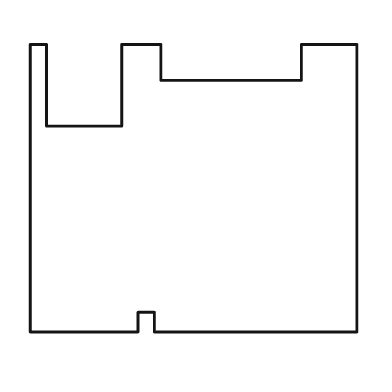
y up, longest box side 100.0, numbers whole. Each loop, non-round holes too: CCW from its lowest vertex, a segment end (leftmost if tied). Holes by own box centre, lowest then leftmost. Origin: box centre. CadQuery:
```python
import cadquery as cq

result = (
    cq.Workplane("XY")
    .moveTo(-50.0, -44.0)
    .lineTo(-17.0, -44.0)
    .lineTo(-17.0, -38.0)
    .lineTo(-12.0, -38.0)
    .lineTo(-12.0, -44.0)
    .lineTo(50.0, -44.0)
    .lineTo(50.0, 44.0)
    .lineTo(33.0, 44.0)
    .lineTo(33.0, 33.0)
    .lineTo(-10.0, 33.0)
    .lineTo(-10.0, 44.0)
    .lineTo(-22.0, 44.0)
    .lineTo(-22.0, 19.0)
    .lineTo(-45.0, 19.0)
    .lineTo(-45.0, 44.0)
    .lineTo(-50.0, 44.0)
    .close()
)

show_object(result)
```